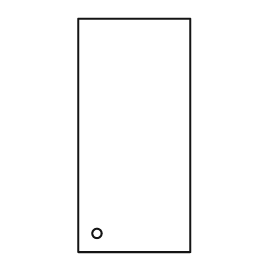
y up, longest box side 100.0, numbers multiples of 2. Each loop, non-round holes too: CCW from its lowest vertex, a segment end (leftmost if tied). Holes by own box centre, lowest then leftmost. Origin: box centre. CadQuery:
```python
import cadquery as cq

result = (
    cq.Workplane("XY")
    .moveTo(-24.0, -50.0)
    .lineTo(24.0, -50.0)
    .lineTo(24.0, 50.0)
    .lineTo(-24.0, 50.0)
    .close()
    .moveTo(-16.0, -42.0)
    .circle(2.0)
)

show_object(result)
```